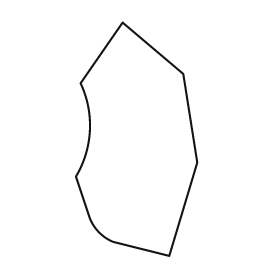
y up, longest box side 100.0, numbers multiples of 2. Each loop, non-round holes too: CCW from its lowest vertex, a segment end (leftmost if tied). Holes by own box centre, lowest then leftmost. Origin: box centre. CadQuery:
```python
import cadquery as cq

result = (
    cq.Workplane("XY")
    .moveTo(14.0, -50.0)
    .lineTo(26.0, -10.0)
    .lineTo(20.0, 28.0)
    .lineTo(-6.0, 50.0)
    .lineTo(-24.0, 24.0)
    .threePointArc((-20.0, 4.0), (-26.0, -16.0))
    .lineTo(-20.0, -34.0)
    .threePointArc((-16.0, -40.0), (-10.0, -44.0))
    .close()
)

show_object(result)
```